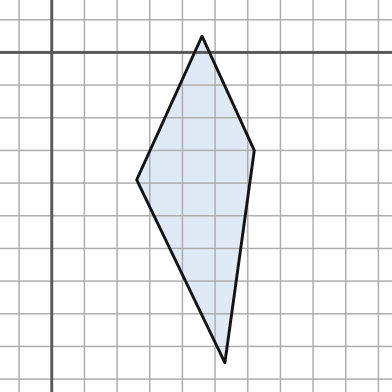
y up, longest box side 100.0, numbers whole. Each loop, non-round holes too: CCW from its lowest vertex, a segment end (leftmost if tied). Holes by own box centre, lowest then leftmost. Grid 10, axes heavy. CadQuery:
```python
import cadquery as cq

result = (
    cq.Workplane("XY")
    .moveTo(53.0, -95.0)
    .lineTo(62.0, -30.0)
    .lineTo(46.0, 5.0)
    .lineTo(26.0, -39.0)
    .close()
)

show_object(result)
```